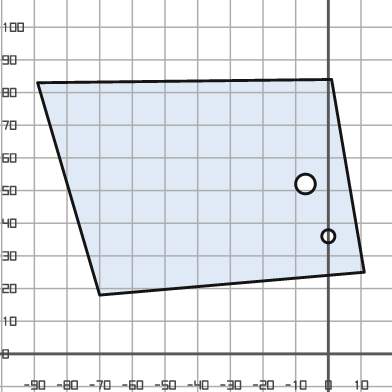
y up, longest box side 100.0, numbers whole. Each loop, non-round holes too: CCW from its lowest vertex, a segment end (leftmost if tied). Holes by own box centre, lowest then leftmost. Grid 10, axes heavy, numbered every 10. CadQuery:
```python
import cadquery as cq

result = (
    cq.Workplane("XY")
    .moveTo(-70.0, 18.0)
    .lineTo(11.0, 25.0)
    .lineTo(1.0, 84.0)
    .lineTo(-89.0, 83.0)
    .close()
    .moveTo(0.0, 36.0)
    .circle(2.0)
    .moveTo(-7.0, 52.0)
    .circle(3.0)
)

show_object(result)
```